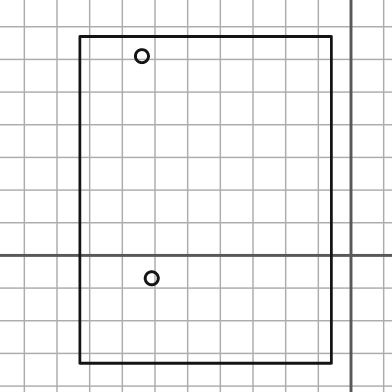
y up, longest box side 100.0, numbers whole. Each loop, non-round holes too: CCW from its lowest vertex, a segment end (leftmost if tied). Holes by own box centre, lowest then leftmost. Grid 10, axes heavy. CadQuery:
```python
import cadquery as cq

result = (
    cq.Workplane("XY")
    .moveTo(-83.0, -33.0)
    .lineTo(-6.0, -33.0)
    .lineTo(-6.0, 67.0)
    .lineTo(-83.0, 67.0)
    .close()
    .moveTo(-61.0, -7.0)
    .circle(2.0)
    .moveTo(-64.0, 61.0)
    .circle(2.0)
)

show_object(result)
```